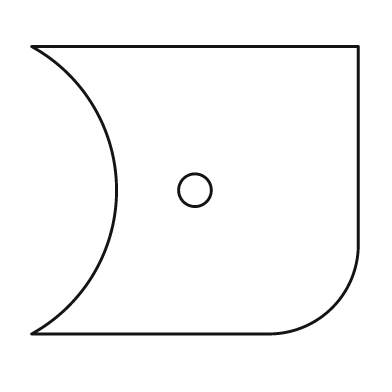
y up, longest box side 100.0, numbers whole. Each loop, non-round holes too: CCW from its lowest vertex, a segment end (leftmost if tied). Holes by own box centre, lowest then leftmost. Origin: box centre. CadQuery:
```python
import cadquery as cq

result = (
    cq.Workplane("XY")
    .moveTo(-50.0, -44.0)
    .lineTo(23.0, -44.0)
    .threePointArc((42.0, -36.0), (50.0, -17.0))
    .lineTo(50.0, 44.0)
    .lineTo(-50.0, 44.0)
    .threePointArc((-24.0, 0.0), (-50.0, -44.0))
    .close()
    .moveTo(0.0, 0.0)
    .circle(5.0)
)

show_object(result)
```